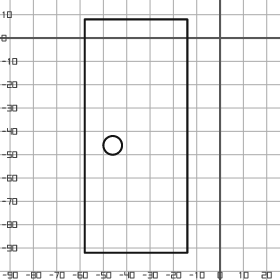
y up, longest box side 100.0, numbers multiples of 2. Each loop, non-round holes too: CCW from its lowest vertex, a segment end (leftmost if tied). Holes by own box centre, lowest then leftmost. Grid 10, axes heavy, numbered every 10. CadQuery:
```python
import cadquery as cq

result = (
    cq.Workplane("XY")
    .moveTo(-58.0, -92.0)
    .lineTo(-14.0, -92.0)
    .lineTo(-14.0, 8.0)
    .lineTo(-58.0, 8.0)
    .close()
    .moveTo(-46.0, -46.0)
    .circle(4.0)
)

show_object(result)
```